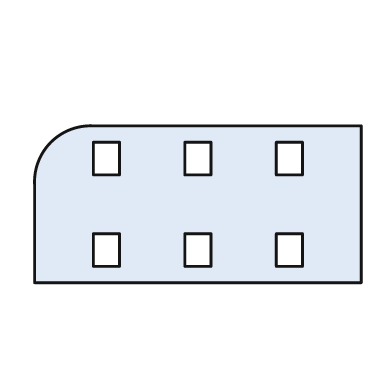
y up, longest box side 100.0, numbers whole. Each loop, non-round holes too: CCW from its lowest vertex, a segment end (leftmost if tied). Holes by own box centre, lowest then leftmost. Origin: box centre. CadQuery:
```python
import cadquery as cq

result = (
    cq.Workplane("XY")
    .moveTo(-50.0, -24.0)
    .lineTo(50.0, -24.0)
    .lineTo(50.0, 24.0)
    .lineTo(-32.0, 24.0)
    .threePointArc((-45.0, 19.0), (-50.0, 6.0))
    .close()
    .moveTo(-32.0, -19.0)
    .lineTo(-24.0, -19.0)
    .lineTo(-24.0, -9.0)
    .lineTo(-32.0, -9.0)
    .close()
    .moveTo(-4.0, -19.0)
    .lineTo(4.0, -19.0)
    .lineTo(4.0, -9.0)
    .lineTo(-4.0, -9.0)
    .close()
    .moveTo(24.0, -19.0)
    .lineTo(32.0, -19.0)
    .lineTo(32.0, -9.0)
    .lineTo(24.0, -9.0)
    .close()
    .moveTo(-32.0, 9.0)
    .lineTo(-24.0, 9.0)
    .lineTo(-24.0, 19.0)
    .lineTo(-32.0, 19.0)
    .close()
    .moveTo(-4.0, 9.0)
    .lineTo(4.0, 9.0)
    .lineTo(4.0, 19.0)
    .lineTo(-4.0, 19.0)
    .close()
    .moveTo(24.0, 9.0)
    .lineTo(32.0, 9.0)
    .lineTo(32.0, 19.0)
    .lineTo(24.0, 19.0)
    .close()
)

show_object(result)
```